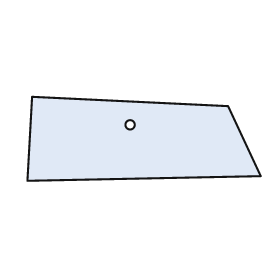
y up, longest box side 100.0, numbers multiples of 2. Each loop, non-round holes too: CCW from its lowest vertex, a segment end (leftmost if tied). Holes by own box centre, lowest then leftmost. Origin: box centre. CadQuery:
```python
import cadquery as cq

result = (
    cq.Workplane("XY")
    .moveTo(-50.0, -18.0)
    .lineTo(50.0, -16.0)
    .lineTo(36.0, 14.0)
    .lineTo(-48.0, 18.0)
    .close()
    .moveTo(-6.0, 6.0)
    .circle(2.0)
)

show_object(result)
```